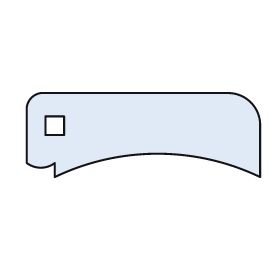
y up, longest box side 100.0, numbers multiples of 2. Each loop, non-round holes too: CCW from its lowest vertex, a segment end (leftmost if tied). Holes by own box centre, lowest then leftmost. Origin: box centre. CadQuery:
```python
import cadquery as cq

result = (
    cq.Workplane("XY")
    .moveTo(-38.0, -18.0)
    .threePointArc((6.0, -8.0), (50.0, -18.0))
    .lineTo(50.0, 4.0)
    .threePointArc((46.0, 14.0), (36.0, 18.0))
    .lineTo(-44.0, 18.0)
    .threePointArc((-48.0, 16.0), (-50.0, 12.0))
    .lineTo(-50.0, -12.0)
    .threePointArc((-44.0, -14.0), (-38.0, -12.0))
    .close()
    .moveTo(-42.0, 0.0)
    .lineTo(-34.0, 0.0)
    .lineTo(-34.0, 8.0)
    .lineTo(-42.0, 8.0)
    .close()
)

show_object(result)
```